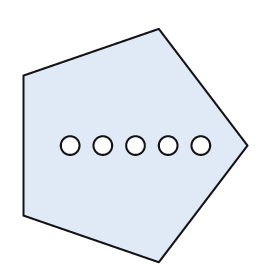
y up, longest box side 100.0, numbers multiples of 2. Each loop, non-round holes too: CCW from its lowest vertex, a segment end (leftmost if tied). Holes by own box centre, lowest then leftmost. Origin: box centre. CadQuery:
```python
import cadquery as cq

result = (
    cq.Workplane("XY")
    .moveTo(10.0, -50.0)
    .lineTo(48.0, 0.0)
    .lineTo(10.0, 50.0)
    .lineTo(-48.0, 30.0)
    .lineTo(-48.0, -30.0)
    .close()
    .moveTo(-28.0, 0.0)
    .circle(4.0)
    .moveTo(-14.0, 0.0)
    .circle(4.0)
    .moveTo(0.0, 0.0)
    .circle(4.0)
    .moveTo(14.0, 0.0)
    .circle(4.0)
    .moveTo(28.0, 0.0)
    .circle(4.0)
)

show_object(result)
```